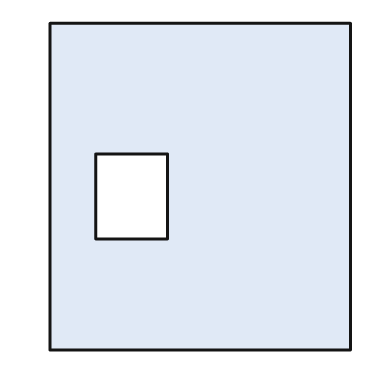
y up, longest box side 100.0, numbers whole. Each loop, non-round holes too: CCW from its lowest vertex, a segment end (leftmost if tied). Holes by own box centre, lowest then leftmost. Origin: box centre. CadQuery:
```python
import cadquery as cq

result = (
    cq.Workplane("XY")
    .moveTo(-46.0, -50.0)
    .lineTo(46.0, -50.0)
    .lineTo(46.0, 50.0)
    .lineTo(-46.0, 50.0)
    .close()
    .moveTo(-32.0, -16.0)
    .lineTo(-10.0, -16.0)
    .lineTo(-10.0, 10.0)
    .lineTo(-32.0, 10.0)
    .close()
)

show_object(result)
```